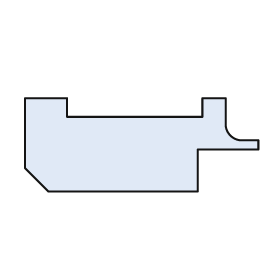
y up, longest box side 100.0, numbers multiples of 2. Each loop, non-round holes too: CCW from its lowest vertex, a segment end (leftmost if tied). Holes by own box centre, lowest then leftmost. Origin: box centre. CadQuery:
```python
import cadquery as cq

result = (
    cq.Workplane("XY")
    .moveTo(-40.0, -20.0)
    .lineTo(24.0, -20.0)
    .lineTo(24.0, -2.0)
    .lineTo(50.0, -2.0)
    .lineTo(50.0, 2.0)
    .lineTo(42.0, 2.0)
    .threePointArc((38.0, 4.0), (36.0, 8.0))
    .lineTo(36.0, 20.0)
    .lineTo(26.0, 20.0)
    .lineTo(26.0, 12.0)
    .lineTo(-32.0, 12.0)
    .lineTo(-32.0, 20.0)
    .lineTo(-50.0, 20.0)
    .lineTo(-50.0, -10.0)
    .close()
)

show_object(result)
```